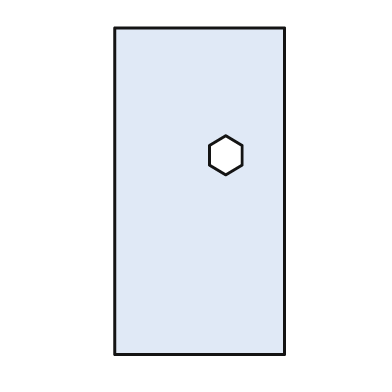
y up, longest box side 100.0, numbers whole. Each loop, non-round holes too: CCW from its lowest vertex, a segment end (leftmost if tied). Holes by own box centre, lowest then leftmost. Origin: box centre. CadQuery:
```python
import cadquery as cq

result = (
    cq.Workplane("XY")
    .moveTo(-26.0, -50.0)
    .lineTo(26.0, -50.0)
    .lineTo(26.0, 50.0)
    .lineTo(-26.0, 50.0)
    .close()
    .moveTo(8.0, 5.0)
    .lineTo(13.0, 8.0)
    .lineTo(13.0, 14.0)
    .lineTo(8.0, 17.0)
    .lineTo(3.0, 14.0)
    .lineTo(3.0, 8.0)
    .close()
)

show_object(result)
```